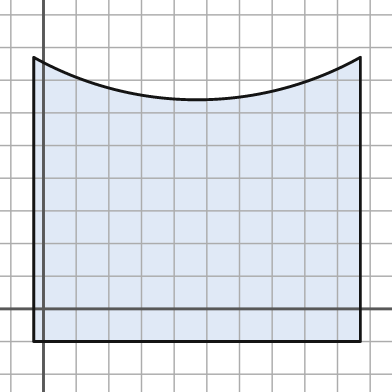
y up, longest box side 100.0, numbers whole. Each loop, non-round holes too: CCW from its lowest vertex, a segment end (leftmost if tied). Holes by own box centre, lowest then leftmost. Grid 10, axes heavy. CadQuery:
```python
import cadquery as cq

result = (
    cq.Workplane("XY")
    .moveTo(-3.0, -10.0)
    .lineTo(97.0, -10.0)
    .lineTo(97.0, 77.0)
    .threePointArc((47.0, 64.0), (-3.0, 77.0))
    .close()
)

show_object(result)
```